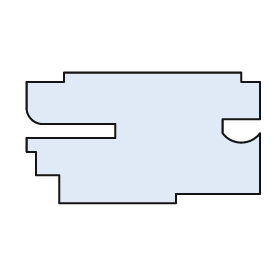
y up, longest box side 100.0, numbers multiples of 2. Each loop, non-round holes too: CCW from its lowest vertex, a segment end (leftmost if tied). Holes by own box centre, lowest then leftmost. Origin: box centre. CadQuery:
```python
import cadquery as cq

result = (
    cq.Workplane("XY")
    .moveTo(-36.0, -28.0)
    .lineTo(14.0, -28.0)
    .lineTo(14.0, -24.0)
    .lineTo(50.0, -24.0)
    .lineTo(50.0, 2.0)
    .threePointArc((42.0, -2.0), (34.0, 2.0))
    .lineTo(34.0, 8.0)
    .lineTo(50.0, 8.0)
    .lineTo(50.0, 24.0)
    .lineTo(42.0, 24.0)
    .lineTo(42.0, 28.0)
    .lineTo(-34.0, 28.0)
    .lineTo(-34.0, 24.0)
    .lineTo(-50.0, 24.0)
    .lineTo(-50.0, 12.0)
    .threePointArc((-48.0, 8.0), (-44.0, 6.0))
    .lineTo(-12.0, 6.0)
    .lineTo(-12.0, 0.0)
    .lineTo(-50.0, 0.0)
    .lineTo(-50.0, -6.0)
    .lineTo(-46.0, -6.0)
    .lineTo(-46.0, -16.0)
    .lineTo(-36.0, -16.0)
    .close()
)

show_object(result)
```